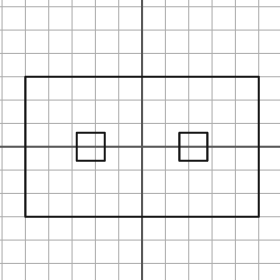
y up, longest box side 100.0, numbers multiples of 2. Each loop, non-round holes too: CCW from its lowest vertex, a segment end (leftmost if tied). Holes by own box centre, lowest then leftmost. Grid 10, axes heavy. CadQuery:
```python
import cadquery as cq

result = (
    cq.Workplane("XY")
    .moveTo(-50.0, -30.0)
    .lineTo(50.0, -30.0)
    .lineTo(50.0, 30.0)
    .lineTo(-50.0, 30.0)
    .close()
    .moveTo(-28.0, -6.0)
    .lineTo(-16.0, -6.0)
    .lineTo(-16.0, 6.0)
    .lineTo(-28.0, 6.0)
    .close()
    .moveTo(16.0, -6.0)
    .lineTo(28.0, -6.0)
    .lineTo(28.0, 6.0)
    .lineTo(16.0, 6.0)
    .close()
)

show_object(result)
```